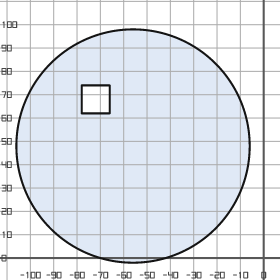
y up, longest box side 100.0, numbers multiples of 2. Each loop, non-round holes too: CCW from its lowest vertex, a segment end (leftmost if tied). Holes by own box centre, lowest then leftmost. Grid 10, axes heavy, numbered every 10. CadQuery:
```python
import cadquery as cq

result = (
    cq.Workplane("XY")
    .moveTo(-56.0, 48.0)
    .circle(50.0)
    .moveTo(-78.0, 62.0)
    .lineTo(-66.0, 62.0)
    .lineTo(-66.0, 74.0)
    .lineTo(-78.0, 74.0)
    .close()
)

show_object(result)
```